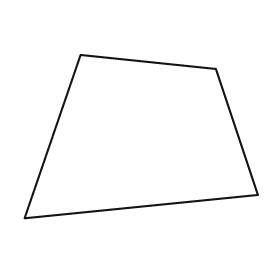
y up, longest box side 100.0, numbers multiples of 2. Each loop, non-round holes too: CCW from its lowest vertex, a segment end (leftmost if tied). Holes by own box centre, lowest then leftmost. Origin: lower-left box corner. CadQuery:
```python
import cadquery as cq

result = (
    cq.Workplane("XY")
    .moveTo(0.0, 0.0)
    .lineTo(100.0, 10.0)
    .lineTo(82.0, 64.0)
    .lineTo(24.0, 70.0)
    .close()
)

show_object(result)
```